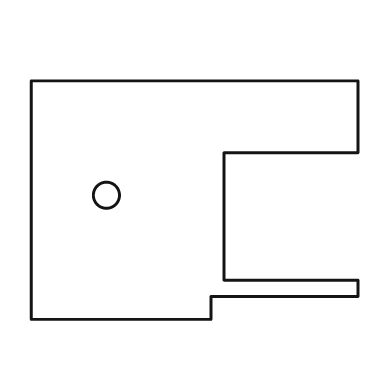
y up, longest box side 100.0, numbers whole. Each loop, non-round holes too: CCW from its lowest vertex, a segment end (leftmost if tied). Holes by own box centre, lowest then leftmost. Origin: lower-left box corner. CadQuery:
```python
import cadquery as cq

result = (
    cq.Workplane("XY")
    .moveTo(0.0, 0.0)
    .lineTo(55.0, 0.0)
    .lineTo(55.0, 7.0)
    .lineTo(100.0, 7.0)
    .lineTo(100.0, 12.0)
    .lineTo(59.0, 12.0)
    .lineTo(59.0, 51.0)
    .lineTo(100.0, 51.0)
    .lineTo(100.0, 73.0)
    .lineTo(0.0, 73.0)
    .close()
    .moveTo(23.0, 38.0)
    .circle(4.0)
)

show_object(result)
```